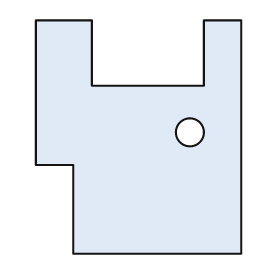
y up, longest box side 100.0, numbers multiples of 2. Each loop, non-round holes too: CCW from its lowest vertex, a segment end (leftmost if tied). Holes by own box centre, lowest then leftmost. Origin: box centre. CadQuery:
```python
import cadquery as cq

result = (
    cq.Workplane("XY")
    .moveTo(-28.0, -50.0)
    .lineTo(44.0, -50.0)
    .lineTo(44.0, 50.0)
    .lineTo(28.0, 50.0)
    .lineTo(28.0, 22.0)
    .lineTo(-20.0, 22.0)
    .lineTo(-20.0, 50.0)
    .lineTo(-44.0, 50.0)
    .lineTo(-44.0, -12.0)
    .lineTo(-28.0, -12.0)
    .close()
    .moveTo(22.0, 2.0)
    .circle(6.0)
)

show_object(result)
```